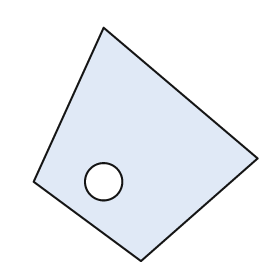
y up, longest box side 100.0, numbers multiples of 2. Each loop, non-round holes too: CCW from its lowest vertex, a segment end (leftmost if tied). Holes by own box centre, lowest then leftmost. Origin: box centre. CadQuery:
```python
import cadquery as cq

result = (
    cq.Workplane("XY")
    .moveTo(-2.0, -50.0)
    .lineTo(48.0, -6.0)
    .lineTo(-18.0, 50.0)
    .lineTo(-48.0, -16.0)
    .close()
    .moveTo(-18.0, -16.0)
    .circle(8.0)
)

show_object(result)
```